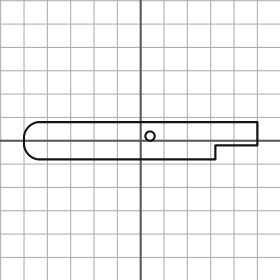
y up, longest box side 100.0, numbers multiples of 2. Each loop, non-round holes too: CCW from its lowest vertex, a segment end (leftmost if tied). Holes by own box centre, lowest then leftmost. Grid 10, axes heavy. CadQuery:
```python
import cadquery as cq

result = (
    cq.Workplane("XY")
    .moveTo(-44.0, -8.0)
    .lineTo(32.0, -8.0)
    .lineTo(32.0, -2.0)
    .lineTo(50.0, -2.0)
    .lineTo(50.0, 8.0)
    .lineTo(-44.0, 8.0)
    .threePointArc((-48.0, 6.0), (-50.0, 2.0))
    .lineTo(-50.0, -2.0)
    .threePointArc((-48.0, -6.0), (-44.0, -8.0))
    .close()
    .moveTo(4.0, 2.0)
    .circle(2.0)
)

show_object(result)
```